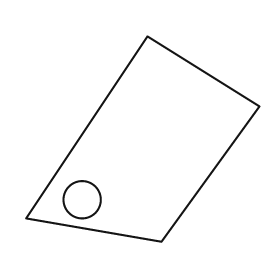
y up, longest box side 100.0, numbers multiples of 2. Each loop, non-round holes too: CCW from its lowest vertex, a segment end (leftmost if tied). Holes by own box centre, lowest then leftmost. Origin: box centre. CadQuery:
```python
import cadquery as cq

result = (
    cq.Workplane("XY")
    .moveTo(8.0, -44.0)
    .lineTo(50.0, 14.0)
    .lineTo(2.0, 44.0)
    .lineTo(-50.0, -34.0)
    .close()
    .moveTo(-26.0, -26.0)
    .circle(8.0)
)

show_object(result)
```